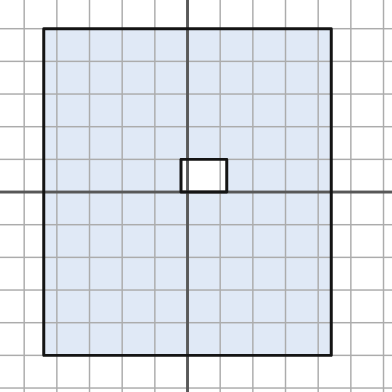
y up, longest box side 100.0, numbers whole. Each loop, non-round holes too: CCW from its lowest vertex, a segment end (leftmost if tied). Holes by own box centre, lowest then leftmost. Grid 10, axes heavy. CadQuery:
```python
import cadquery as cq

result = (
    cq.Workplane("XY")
    .moveTo(-44.0, -50.0)
    .lineTo(44.0, -50.0)
    .lineTo(44.0, 50.0)
    .lineTo(-44.0, 50.0)
    .close()
    .moveTo(-2.0, 0.0)
    .lineTo(12.0, 0.0)
    .lineTo(12.0, 10.0)
    .lineTo(-2.0, 10.0)
    .close()
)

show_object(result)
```